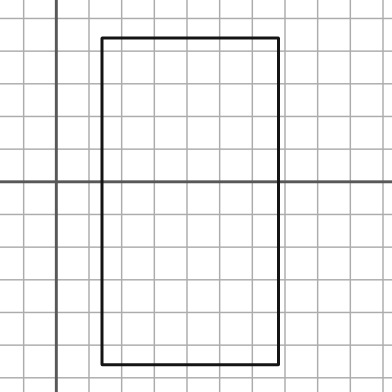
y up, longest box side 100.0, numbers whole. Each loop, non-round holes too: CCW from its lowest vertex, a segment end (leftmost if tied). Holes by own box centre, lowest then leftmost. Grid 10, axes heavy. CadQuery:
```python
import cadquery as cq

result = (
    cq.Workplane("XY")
    .moveTo(14.0, -56.0)
    .lineTo(68.0, -56.0)
    .lineTo(68.0, 44.0)
    .lineTo(14.0, 44.0)
    .close()
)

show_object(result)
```